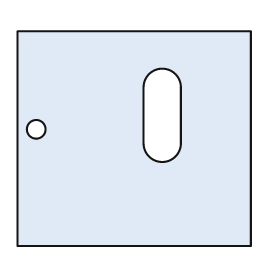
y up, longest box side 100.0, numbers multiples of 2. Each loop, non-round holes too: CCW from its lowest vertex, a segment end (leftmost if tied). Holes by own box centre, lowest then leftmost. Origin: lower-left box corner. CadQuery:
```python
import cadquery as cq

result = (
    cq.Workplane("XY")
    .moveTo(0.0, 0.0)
    .lineTo(100.0, 0.0)
    .lineTo(100.0, 92.0)
    .lineTo(0.0, 92.0)
    .close()
    .moveTo(8.0, 50.0)
    .circle(4.0)
    .moveTo(54.0, 44.0)
    .threePointArc((62.0, 36.0), (70.0, 44.0))
    .lineTo(70.0, 68.0)
    .threePointArc((62.0, 76.0), (54.0, 68.0))
    .close()
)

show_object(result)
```